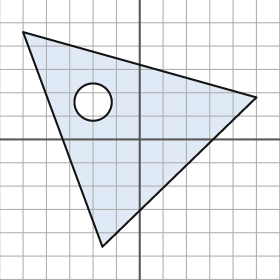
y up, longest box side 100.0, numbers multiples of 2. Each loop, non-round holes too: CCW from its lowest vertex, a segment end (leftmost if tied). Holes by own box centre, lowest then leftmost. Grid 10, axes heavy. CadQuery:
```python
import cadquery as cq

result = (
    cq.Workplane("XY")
    .moveTo(-16.0, -46.0)
    .lineTo(50.0, 18.0)
    .lineTo(-50.0, 46.0)
    .close()
    .moveTo(-20.0, 16.0)
    .circle(8.0)
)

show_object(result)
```